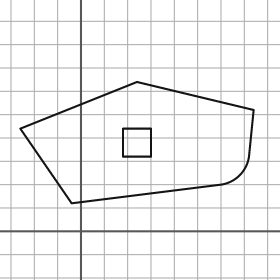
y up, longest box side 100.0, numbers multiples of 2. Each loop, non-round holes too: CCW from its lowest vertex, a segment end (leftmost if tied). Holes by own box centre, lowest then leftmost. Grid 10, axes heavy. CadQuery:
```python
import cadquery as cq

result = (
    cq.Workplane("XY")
    .moveTo(-4.0, 12.0)
    .lineTo(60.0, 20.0)
    .threePointArc((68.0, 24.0), (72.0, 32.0))
    .lineTo(74.0, 52.0)
    .lineTo(24.0, 64.0)
    .lineTo(-26.0, 44.0)
    .close()
    .moveTo(18.0, 32.0)
    .lineTo(30.0, 32.0)
    .lineTo(30.0, 44.0)
    .lineTo(18.0, 44.0)
    .close()
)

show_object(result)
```